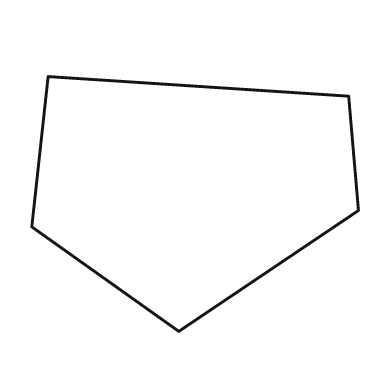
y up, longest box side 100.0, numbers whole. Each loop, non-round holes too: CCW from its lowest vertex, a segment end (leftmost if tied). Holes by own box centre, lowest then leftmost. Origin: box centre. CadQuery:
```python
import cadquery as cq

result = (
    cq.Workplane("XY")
    .moveTo(-5.0, -39.0)
    .lineTo(50.0, -2.0)
    .lineTo(47.0, 33.0)
    .lineTo(-45.0, 39.0)
    .lineTo(-50.0, -7.0)
    .close()
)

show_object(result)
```